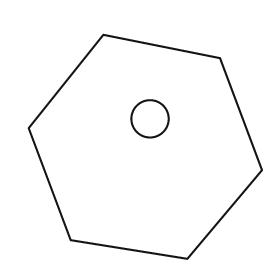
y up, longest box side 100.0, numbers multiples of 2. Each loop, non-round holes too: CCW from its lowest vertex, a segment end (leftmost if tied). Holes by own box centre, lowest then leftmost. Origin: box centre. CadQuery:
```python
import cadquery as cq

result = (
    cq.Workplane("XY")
    .moveTo(18.0, -48.0)
    .lineTo(50.0, -10.0)
    .lineTo(32.0, 38.0)
    .lineTo(-18.0, 48.0)
    .lineTo(-50.0, 8.0)
    .lineTo(-32.0, -40.0)
    .close()
    .moveTo(2.0, 12.0)
    .circle(8.0)
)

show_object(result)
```